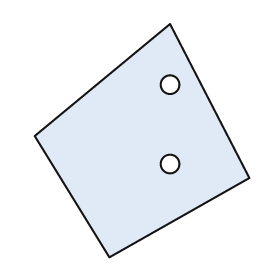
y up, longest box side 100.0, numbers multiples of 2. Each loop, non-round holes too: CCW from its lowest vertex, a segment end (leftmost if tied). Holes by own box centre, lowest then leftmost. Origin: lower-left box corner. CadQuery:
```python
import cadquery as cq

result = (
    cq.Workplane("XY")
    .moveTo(32.0, 0.0)
    .lineTo(92.0, 34.0)
    .lineTo(58.0, 100.0)
    .lineTo(0.0, 52.0)
    .close()
    .moveTo(58.0, 40.0)
    .circle(4.0)
    .moveTo(58.0, 74.0)
    .circle(4.0)
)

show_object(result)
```